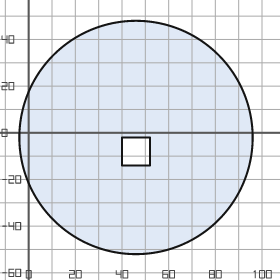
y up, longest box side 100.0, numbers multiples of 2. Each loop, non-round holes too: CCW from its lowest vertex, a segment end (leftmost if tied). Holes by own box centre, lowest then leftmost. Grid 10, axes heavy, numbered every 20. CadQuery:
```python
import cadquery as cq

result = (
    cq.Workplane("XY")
    .moveTo(46.0, -2.0)
    .circle(50.0)
    .moveTo(40.0, -14.0)
    .lineTo(52.0, -14.0)
    .lineTo(52.0, -2.0)
    .lineTo(40.0, -2.0)
    .close()
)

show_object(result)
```